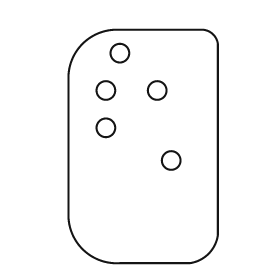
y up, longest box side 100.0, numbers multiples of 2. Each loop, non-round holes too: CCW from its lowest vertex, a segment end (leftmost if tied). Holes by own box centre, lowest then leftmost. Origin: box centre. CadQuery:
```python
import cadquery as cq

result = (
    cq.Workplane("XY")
    .moveTo(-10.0, -50.0)
    .lineTo(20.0, -50.0)
    .threePointArc((28.0, -46.0), (32.0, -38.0))
    .lineTo(32.0, 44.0)
    .threePointArc((30.0, 48.0), (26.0, 50.0))
    .lineTo(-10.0, 50.0)
    .threePointArc((-26.0, 44.0), (-32.0, 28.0))
    .lineTo(-32.0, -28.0)
    .threePointArc((-26.0, -44.0), (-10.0, -50.0))
    .close()
    .moveTo(12.0, -6.0)
    .circle(4.0)
    .moveTo(-16.0, 8.0)
    .circle(4.0)
    .moveTo(-16.0, 24.0)
    .circle(4.0)
    .moveTo(6.0, 24.0)
    .circle(4.0)
    .moveTo(-10.0, 40.0)
    .circle(4.0)
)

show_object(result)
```